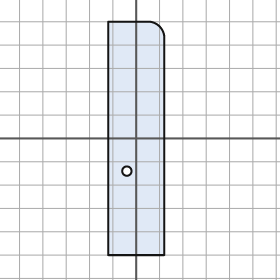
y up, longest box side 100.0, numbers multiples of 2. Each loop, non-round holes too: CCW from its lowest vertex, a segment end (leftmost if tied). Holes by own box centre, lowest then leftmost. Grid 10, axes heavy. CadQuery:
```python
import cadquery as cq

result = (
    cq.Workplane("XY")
    .moveTo(-12.0, -50.0)
    .lineTo(12.0, -50.0)
    .lineTo(12.0, 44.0)
    .threePointArc((10.0, 48.0), (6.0, 50.0))
    .lineTo(-12.0, 50.0)
    .close()
    .moveTo(-4.0, -14.0)
    .circle(2.0)
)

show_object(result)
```